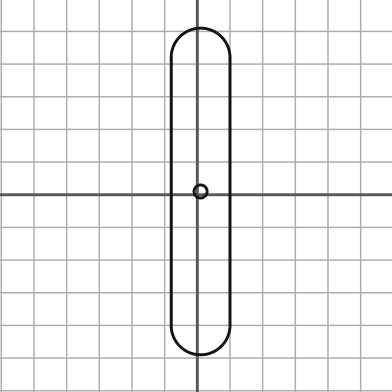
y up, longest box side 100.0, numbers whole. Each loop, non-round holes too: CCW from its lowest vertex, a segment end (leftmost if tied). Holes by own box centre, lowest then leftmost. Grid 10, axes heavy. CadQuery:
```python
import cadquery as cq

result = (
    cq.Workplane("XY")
    .moveTo(-8.0, -40.0)
    .threePointArc((1.0, -49.0), (10.0, -40.0))
    .lineTo(10.0, 42.0)
    .threePointArc((1.0, 51.0), (-8.0, 42.0))
    .close()
    .moveTo(1.0, 1.0)
    .circle(2.0)
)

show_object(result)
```